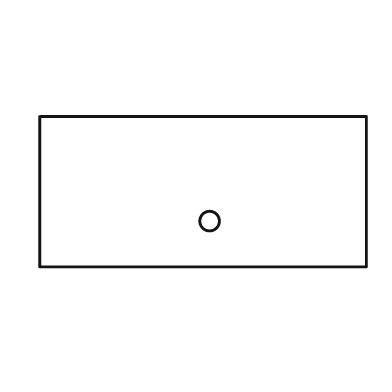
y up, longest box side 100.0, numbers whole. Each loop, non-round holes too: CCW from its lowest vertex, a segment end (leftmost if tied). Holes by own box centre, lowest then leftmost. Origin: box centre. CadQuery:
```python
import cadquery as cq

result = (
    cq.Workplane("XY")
    .moveTo(-50.0, -23.0)
    .lineTo(50.0, -23.0)
    .lineTo(50.0, 23.0)
    .lineTo(-50.0, 23.0)
    .close()
    .moveTo(2.0, -9.0)
    .circle(3.0)
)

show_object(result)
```